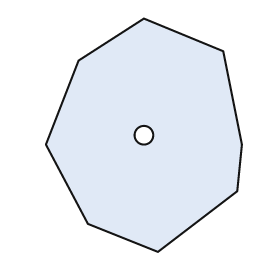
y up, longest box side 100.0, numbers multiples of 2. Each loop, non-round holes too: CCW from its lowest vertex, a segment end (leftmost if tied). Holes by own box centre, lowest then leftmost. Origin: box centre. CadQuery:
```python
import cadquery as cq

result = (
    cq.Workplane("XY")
    .moveTo(6.0, -50.0)
    .lineTo(40.0, -24.0)
    .lineTo(42.0, -4.0)
    .lineTo(34.0, 36.0)
    .lineTo(0.0, 50.0)
    .lineTo(-28.0, 32.0)
    .lineTo(-42.0, -4.0)
    .lineTo(-24.0, -38.0)
    .close()
    .moveTo(0.0, 0.0)
    .circle(4.0)
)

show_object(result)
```